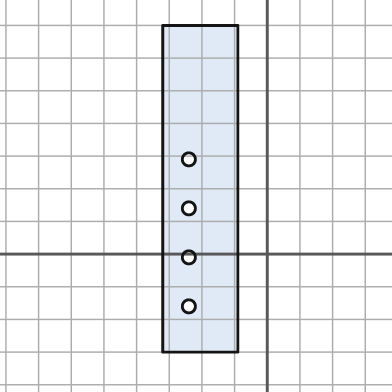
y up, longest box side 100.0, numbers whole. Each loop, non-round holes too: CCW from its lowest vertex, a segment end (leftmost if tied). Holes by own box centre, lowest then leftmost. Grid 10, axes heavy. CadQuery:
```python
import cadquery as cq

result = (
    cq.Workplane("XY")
    .moveTo(-32.0, -30.0)
    .lineTo(-9.0, -30.0)
    .lineTo(-9.0, 70.0)
    .lineTo(-32.0, 70.0)
    .close()
    .moveTo(-24.0, -16.0)
    .circle(2.0)
    .moveTo(-24.0, -1.0)
    .circle(2.0)
    .moveTo(-24.0, 14.0)
    .circle(2.0)
    .moveTo(-24.0, 29.0)
    .circle(2.0)
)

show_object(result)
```